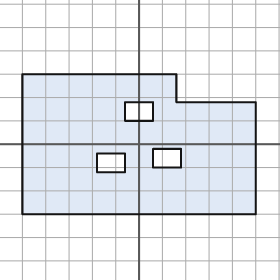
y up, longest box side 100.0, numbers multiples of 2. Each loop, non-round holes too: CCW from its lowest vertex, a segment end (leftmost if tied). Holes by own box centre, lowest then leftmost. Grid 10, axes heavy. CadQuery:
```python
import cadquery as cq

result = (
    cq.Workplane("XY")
    .moveTo(-50.0, -30.0)
    .lineTo(50.0, -30.0)
    .lineTo(50.0, 18.0)
    .lineTo(16.0, 18.0)
    .lineTo(16.0, 30.0)
    .lineTo(-50.0, 30.0)
    .close()
    .moveTo(-18.0, -12.0)
    .lineTo(-6.0, -12.0)
    .lineTo(-6.0, -4.0)
    .lineTo(-18.0, -4.0)
    .close()
    .moveTo(6.0, -10.0)
    .lineTo(18.0, -10.0)
    .lineTo(18.0, -2.0)
    .lineTo(6.0, -2.0)
    .close()
    .moveTo(-6.0, 10.0)
    .lineTo(6.0, 10.0)
    .lineTo(6.0, 18.0)
    .lineTo(-6.0, 18.0)
    .close()
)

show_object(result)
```